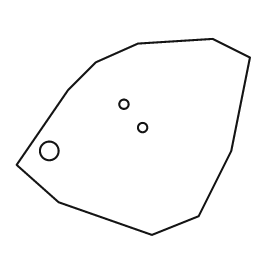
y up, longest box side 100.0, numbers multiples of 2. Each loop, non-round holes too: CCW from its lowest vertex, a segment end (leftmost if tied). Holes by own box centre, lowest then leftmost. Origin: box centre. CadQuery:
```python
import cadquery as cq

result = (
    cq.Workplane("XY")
    .moveTo(8.0, -42.0)
    .lineTo(28.0, -34.0)
    .lineTo(42.0, -6.0)
    .lineTo(50.0, 34.0)
    .lineTo(34.0, 42.0)
    .lineTo(2.0, 40.0)
    .lineTo(-16.0, 32.0)
    .lineTo(-28.0, 20.0)
    .lineTo(-50.0, -12.0)
    .lineTo(-32.0, -28.0)
    .close()
    .moveTo(-36.0, -6.0)
    .circle(4.0)
    .moveTo(4.0, 4.0)
    .circle(2.0)
    .moveTo(-4.0, 14.0)
    .circle(2.0)
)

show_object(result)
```